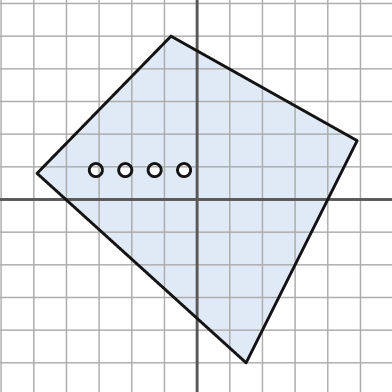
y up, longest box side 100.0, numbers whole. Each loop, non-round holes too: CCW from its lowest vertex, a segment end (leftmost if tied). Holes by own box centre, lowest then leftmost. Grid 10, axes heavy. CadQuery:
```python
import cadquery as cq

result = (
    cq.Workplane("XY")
    .moveTo(15.0, -50.0)
    .lineTo(49.0, 18.0)
    .lineTo(-8.0, 50.0)
    .lineTo(-49.0, 8.0)
    .close()
    .moveTo(-31.0, 9.0)
    .circle(2.0)
    .moveTo(-22.0, 9.0)
    .circle(2.0)
    .moveTo(-13.0, 9.0)
    .circle(2.0)
    .moveTo(-4.0, 9.0)
    .circle(2.0)
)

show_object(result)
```